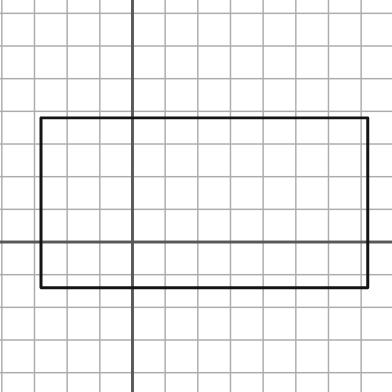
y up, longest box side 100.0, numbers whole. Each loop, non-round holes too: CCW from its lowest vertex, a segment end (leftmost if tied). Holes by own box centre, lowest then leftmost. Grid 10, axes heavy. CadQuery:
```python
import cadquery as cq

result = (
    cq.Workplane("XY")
    .moveTo(-28.0, -14.0)
    .lineTo(72.0, -14.0)
    .lineTo(72.0, 38.0)
    .lineTo(-28.0, 38.0)
    .close()
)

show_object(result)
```